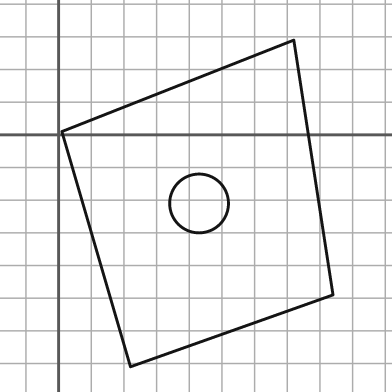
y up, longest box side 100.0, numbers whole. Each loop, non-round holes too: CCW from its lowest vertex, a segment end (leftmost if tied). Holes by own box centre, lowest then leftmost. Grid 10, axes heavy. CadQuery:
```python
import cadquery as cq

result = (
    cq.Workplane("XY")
    .moveTo(22.0, -71.0)
    .lineTo(84.0, -49.0)
    .lineTo(72.0, 29.0)
    .lineTo(1.0, 1.0)
    .close()
    .moveTo(43.0, -21.0)
    .circle(9.0)
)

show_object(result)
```